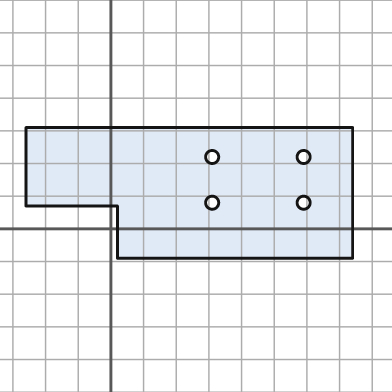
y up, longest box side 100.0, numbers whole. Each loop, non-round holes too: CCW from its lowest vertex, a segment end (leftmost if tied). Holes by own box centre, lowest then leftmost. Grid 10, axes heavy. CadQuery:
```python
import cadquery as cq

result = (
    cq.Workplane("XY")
    .moveTo(2.0, -9.0)
    .lineTo(74.0, -9.0)
    .lineTo(74.0, 31.0)
    .lineTo(-26.0, 31.0)
    .lineTo(-26.0, 7.0)
    .lineTo(2.0, 7.0)
    .close()
    .moveTo(31.0, 8.0)
    .circle(2.0)
    .moveTo(59.0, 8.0)
    .circle(2.0)
    .moveTo(31.0, 22.0)
    .circle(2.0)
    .moveTo(59.0, 22.0)
    .circle(2.0)
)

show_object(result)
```